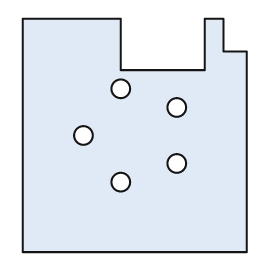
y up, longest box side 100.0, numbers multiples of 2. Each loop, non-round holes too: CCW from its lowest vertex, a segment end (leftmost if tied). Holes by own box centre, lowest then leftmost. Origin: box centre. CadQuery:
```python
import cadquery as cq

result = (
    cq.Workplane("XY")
    .moveTo(-48.0, -50.0)
    .lineTo(48.0, -50.0)
    .lineTo(48.0, 36.0)
    .lineTo(38.0, 36.0)
    .lineTo(38.0, 50.0)
    .lineTo(30.0, 50.0)
    .lineTo(30.0, 28.0)
    .lineTo(-6.0, 28.0)
    .lineTo(-6.0, 50.0)
    .lineTo(-48.0, 50.0)
    .close()
    .moveTo(-6.0, -20.0)
    .circle(4.0)
    .moveTo(18.0, -12.0)
    .circle(4.0)
    .moveTo(-22.0, 0.0)
    .circle(4.0)
    .moveTo(18.0, 12.0)
    .circle(4.0)
    .moveTo(-6.0, 20.0)
    .circle(4.0)
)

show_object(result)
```